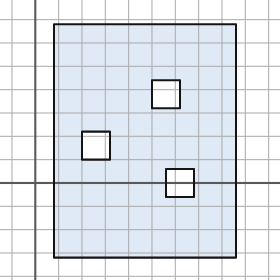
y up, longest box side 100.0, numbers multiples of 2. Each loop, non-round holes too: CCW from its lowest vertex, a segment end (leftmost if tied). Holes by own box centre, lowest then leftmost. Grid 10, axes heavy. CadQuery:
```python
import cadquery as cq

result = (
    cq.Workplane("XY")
    .moveTo(8.0, -32.0)
    .lineTo(86.0, -32.0)
    .lineTo(86.0, 68.0)
    .lineTo(8.0, 68.0)
    .close()
    .moveTo(56.0, -6.0)
    .lineTo(68.0, -6.0)
    .lineTo(68.0, 6.0)
    .lineTo(56.0, 6.0)
    .close()
    .moveTo(20.0, 10.0)
    .lineTo(32.0, 10.0)
    .lineTo(32.0, 22.0)
    .lineTo(20.0, 22.0)
    .close()
    .moveTo(50.0, 32.0)
    .lineTo(62.0, 32.0)
    .lineTo(62.0, 44.0)
    .lineTo(50.0, 44.0)
    .close()
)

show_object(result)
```